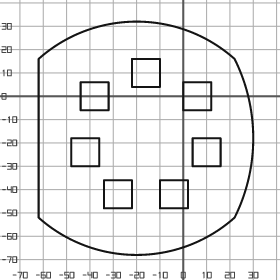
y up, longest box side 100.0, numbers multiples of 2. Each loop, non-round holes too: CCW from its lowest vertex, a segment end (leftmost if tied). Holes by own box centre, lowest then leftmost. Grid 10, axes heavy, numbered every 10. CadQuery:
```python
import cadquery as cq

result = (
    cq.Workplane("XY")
    .moveTo(-62.0, -52.0)
    .threePointArc((-20.0, -68.0), (22.0, -52.0))
    .threePointArc((30.0, -18.0), (22.0, 16.0))
    .threePointArc((-20.0, 32.0), (-62.0, 16.0))
    .close()
    .moveTo(-34.0, -48.0)
    .lineTo(-22.0, -48.0)
    .lineTo(-22.0, -36.0)
    .lineTo(-34.0, -36.0)
    .close()
    .moveTo(-10.0, -48.0)
    .lineTo(2.0, -48.0)
    .lineTo(2.0, -36.0)
    .lineTo(-10.0, -36.0)
    .close()
    .moveTo(-48.0, -30.0)
    .lineTo(-36.0, -30.0)
    .lineTo(-36.0, -18.0)
    .lineTo(-48.0, -18.0)
    .close()
    .moveTo(4.0, -30.0)
    .lineTo(16.0, -30.0)
    .lineTo(16.0, -18.0)
    .lineTo(4.0, -18.0)
    .close()
    .moveTo(-44.0, -6.0)
    .lineTo(-32.0, -6.0)
    .lineTo(-32.0, 6.0)
    .lineTo(-44.0, 6.0)
    .close()
    .moveTo(0.0, -6.0)
    .lineTo(12.0, -6.0)
    .lineTo(12.0, 6.0)
    .lineTo(0.0, 6.0)
    .close()
    .moveTo(-22.0, 4.0)
    .lineTo(-10.0, 4.0)
    .lineTo(-10.0, 16.0)
    .lineTo(-22.0, 16.0)
    .close()
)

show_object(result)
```